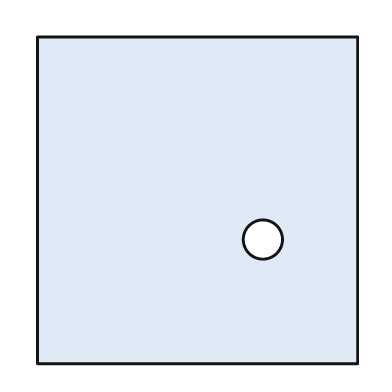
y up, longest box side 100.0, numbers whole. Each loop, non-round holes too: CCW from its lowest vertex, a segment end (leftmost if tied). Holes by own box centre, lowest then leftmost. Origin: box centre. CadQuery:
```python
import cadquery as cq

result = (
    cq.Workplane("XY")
    .moveTo(-49.0, -50.0)
    .lineTo(49.0, -50.0)
    .lineTo(49.0, 50.0)
    .lineTo(-49.0, 50.0)
    .close()
    .moveTo(20.0, -12.0)
    .circle(6.0)
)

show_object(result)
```